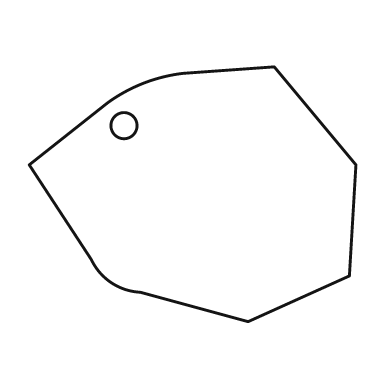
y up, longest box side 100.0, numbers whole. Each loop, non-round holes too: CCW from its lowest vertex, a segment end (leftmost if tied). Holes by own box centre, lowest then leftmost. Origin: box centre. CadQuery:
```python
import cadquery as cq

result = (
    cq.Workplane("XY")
    .moveTo(17.0, -39.0)
    .lineTo(48.0, -25.0)
    .lineTo(50.0, 9.0)
    .lineTo(25.0, 39.0)
    .lineTo(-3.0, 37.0)
    .threePointArc((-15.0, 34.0), (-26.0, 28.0))
    .lineTo(-50.0, 9.0)
    .lineTo(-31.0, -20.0)
    .threePointArc((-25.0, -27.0), (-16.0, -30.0))
    .close()
    .moveTo(-21.0, 21.0)
    .circle(4.0)
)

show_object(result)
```